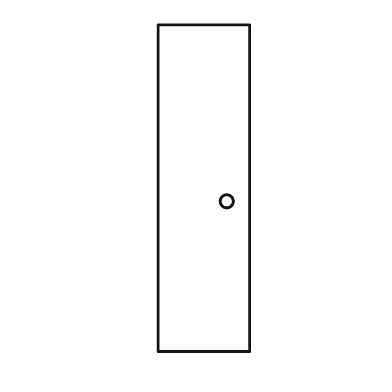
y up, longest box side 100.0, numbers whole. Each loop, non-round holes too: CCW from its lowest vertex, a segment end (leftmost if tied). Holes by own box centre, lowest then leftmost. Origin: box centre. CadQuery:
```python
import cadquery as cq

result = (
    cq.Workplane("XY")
    .moveTo(-14.0, -50.0)
    .lineTo(14.0, -50.0)
    .lineTo(14.0, 50.0)
    .lineTo(-14.0, 50.0)
    .close()
    .moveTo(7.0, -4.0)
    .circle(2.0)
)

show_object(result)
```